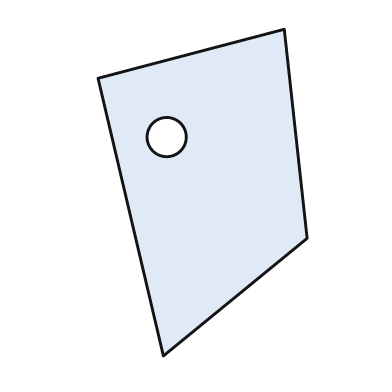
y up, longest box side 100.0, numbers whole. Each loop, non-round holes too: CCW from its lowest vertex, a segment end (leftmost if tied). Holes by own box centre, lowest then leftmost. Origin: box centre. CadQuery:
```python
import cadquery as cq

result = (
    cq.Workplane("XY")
    .moveTo(-12.0, -50.0)
    .lineTo(32.0, -14.0)
    .lineTo(25.0, 50.0)
    .lineTo(-32.0, 35.0)
    .close()
    .moveTo(-11.0, 17.0)
    .circle(6.0)
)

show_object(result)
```